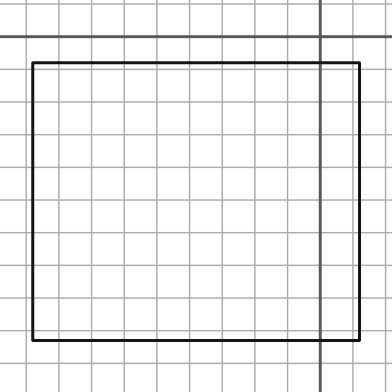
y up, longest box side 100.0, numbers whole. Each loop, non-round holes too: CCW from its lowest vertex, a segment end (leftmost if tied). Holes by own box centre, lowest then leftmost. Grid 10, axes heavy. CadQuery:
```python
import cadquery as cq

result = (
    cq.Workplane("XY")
    .moveTo(-88.0, -93.0)
    .lineTo(12.0, -93.0)
    .lineTo(12.0, -8.0)
    .lineTo(-88.0, -8.0)
    .close()
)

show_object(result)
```